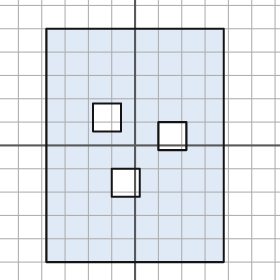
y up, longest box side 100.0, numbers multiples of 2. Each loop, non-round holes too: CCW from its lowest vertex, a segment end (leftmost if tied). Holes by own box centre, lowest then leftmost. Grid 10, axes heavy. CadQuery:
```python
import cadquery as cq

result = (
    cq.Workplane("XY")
    .moveTo(-38.0, -50.0)
    .lineTo(38.0, -50.0)
    .lineTo(38.0, 50.0)
    .lineTo(-38.0, 50.0)
    .close()
    .moveTo(-10.0, -22.0)
    .lineTo(2.0, -22.0)
    .lineTo(2.0, -10.0)
    .lineTo(-10.0, -10.0)
    .close()
    .moveTo(10.0, -2.0)
    .lineTo(22.0, -2.0)
    .lineTo(22.0, 10.0)
    .lineTo(10.0, 10.0)
    .close()
    .moveTo(-18.0, 6.0)
    .lineTo(-6.0, 6.0)
    .lineTo(-6.0, 18.0)
    .lineTo(-18.0, 18.0)
    .close()
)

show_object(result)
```